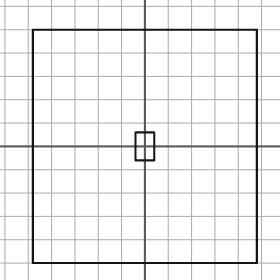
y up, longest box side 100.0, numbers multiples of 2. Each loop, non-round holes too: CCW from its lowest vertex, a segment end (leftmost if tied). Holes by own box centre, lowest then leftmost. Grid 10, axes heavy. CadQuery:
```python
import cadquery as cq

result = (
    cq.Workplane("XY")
    .moveTo(-48.0, -50.0)
    .lineTo(48.0, -50.0)
    .lineTo(48.0, 50.0)
    .lineTo(-48.0, 50.0)
    .close()
    .moveTo(-4.0, -6.0)
    .lineTo(4.0, -6.0)
    .lineTo(4.0, 6.0)
    .lineTo(-4.0, 6.0)
    .close()
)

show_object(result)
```